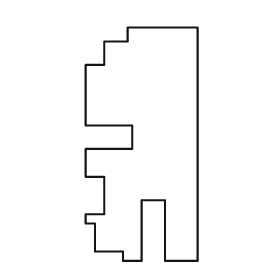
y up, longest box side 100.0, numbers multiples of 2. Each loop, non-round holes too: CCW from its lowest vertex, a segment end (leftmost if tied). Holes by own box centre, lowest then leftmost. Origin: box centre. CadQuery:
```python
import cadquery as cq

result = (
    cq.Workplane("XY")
    .moveTo(-8.0, -50.0)
    .lineTo(0.0, -50.0)
    .lineTo(0.0, -24.0)
    .lineTo(10.0, -24.0)
    .lineTo(10.0, -50.0)
    .lineTo(24.0, -50.0)
    .lineTo(24.0, 50.0)
    .lineTo(-6.0, 50.0)
    .lineTo(-6.0, 44.0)
    .lineTo(-16.0, 44.0)
    .lineTo(-16.0, 34.0)
    .lineTo(-24.0, 34.0)
    .lineTo(-24.0, 8.0)
    .lineTo(-4.0, 8.0)
    .lineTo(-4.0, -2.0)
    .lineTo(-24.0, -2.0)
    .lineTo(-24.0, -14.0)
    .lineTo(-16.0, -14.0)
    .lineTo(-16.0, -30.0)
    .lineTo(-24.0, -30.0)
    .lineTo(-24.0, -34.0)
    .lineTo(-20.0, -34.0)
    .lineTo(-20.0, -46.0)
    .lineTo(-8.0, -46.0)
    .close()
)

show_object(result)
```